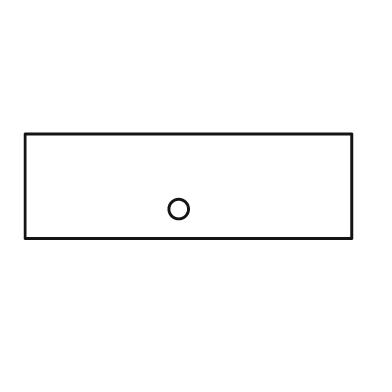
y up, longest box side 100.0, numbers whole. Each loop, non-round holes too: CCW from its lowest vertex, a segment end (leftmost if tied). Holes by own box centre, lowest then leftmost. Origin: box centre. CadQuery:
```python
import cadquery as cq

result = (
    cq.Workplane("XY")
    .moveTo(-50.0, -16.0)
    .lineTo(50.0, -16.0)
    .lineTo(50.0, 16.0)
    .lineTo(-50.0, 16.0)
    .close()
    .moveTo(-3.0, -7.0)
    .circle(3.0)
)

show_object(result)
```